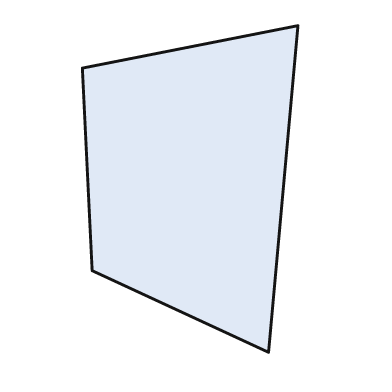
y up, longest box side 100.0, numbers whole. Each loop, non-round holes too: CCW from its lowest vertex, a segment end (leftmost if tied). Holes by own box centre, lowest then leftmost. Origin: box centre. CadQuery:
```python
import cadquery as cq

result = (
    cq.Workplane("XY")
    .moveTo(24.0, -50.0)
    .lineTo(33.0, 50.0)
    .lineTo(-33.0, 37.0)
    .lineTo(-30.0, -25.0)
    .close()
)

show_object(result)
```